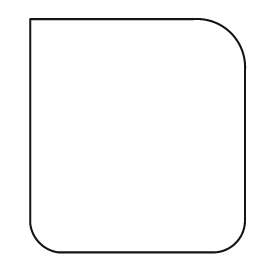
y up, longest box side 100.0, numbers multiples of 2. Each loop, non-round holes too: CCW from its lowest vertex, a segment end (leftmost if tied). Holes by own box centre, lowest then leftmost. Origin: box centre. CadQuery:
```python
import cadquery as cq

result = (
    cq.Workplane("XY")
    .moveTo(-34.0, -50.0)
    .lineTo(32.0, -50.0)
    .threePointArc((42.0, -46.0), (46.0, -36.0))
    .lineTo(46.0, 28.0)
    .threePointArc((40.0, 44.0), (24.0, 50.0))
    .lineTo(-46.0, 50.0)
    .lineTo(-46.0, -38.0)
    .threePointArc((-42.0, -46.0), (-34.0, -50.0))
    .close()
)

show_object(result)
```